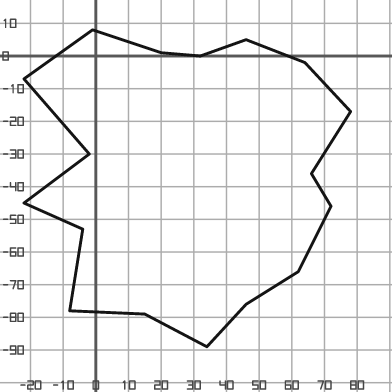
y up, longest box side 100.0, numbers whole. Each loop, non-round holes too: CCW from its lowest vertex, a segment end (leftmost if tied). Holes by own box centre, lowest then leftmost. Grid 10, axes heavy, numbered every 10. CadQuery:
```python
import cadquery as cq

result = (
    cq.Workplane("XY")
    .moveTo(34.0, -89.0)
    .lineTo(46.0, -76.0)
    .lineTo(62.0, -66.0)
    .lineTo(72.0, -46.0)
    .lineTo(66.0, -36.0)
    .lineTo(78.0, -17.0)
    .lineTo(64.0, -2.0)
    .lineTo(46.0, 5.0)
    .lineTo(32.0, 0.0)
    .lineTo(20.0, 1.0)
    .lineTo(-1.0, 8.0)
    .lineTo(-22.0, -7.0)
    .lineTo(-2.0, -30.0)
    .lineTo(-22.0, -45.0)
    .lineTo(-4.0, -53.0)
    .lineTo(-8.0, -78.0)
    .lineTo(15.0, -79.0)
    .close()
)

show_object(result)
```